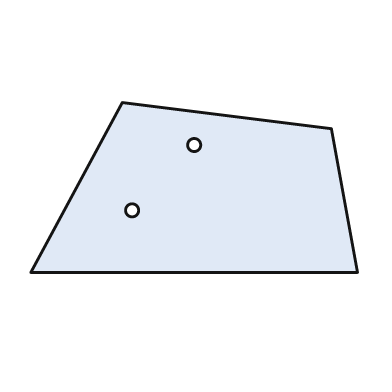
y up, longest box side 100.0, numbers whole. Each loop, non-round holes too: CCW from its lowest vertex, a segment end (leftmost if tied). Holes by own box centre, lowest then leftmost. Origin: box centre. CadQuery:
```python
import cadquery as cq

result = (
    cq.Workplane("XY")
    .moveTo(-50.0, -26.0)
    .lineTo(50.0, -26.0)
    .lineTo(42.0, 18.0)
    .lineTo(-22.0, 26.0)
    .close()
    .moveTo(-19.0, -7.0)
    .circle(2.0)
    .moveTo(0.0, 13.0)
    .circle(2.0)
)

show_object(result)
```